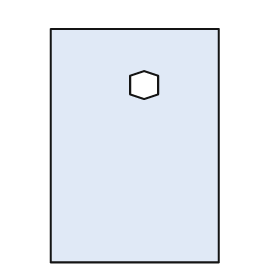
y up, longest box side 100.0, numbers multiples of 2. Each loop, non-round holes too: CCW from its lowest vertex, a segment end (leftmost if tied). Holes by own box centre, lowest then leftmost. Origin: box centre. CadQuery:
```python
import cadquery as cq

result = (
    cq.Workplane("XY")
    .moveTo(-36.0, -50.0)
    .lineTo(36.0, -50.0)
    .lineTo(36.0, 50.0)
    .lineTo(-36.0, 50.0)
    .close()
    .moveTo(4.0, 20.0)
    .lineTo(10.0, 22.0)
    .lineTo(10.0, 30.0)
    .lineTo(4.0, 32.0)
    .lineTo(-2.0, 30.0)
    .lineTo(-2.0, 22.0)
    .close()
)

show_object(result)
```